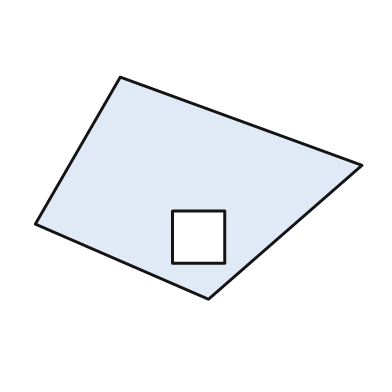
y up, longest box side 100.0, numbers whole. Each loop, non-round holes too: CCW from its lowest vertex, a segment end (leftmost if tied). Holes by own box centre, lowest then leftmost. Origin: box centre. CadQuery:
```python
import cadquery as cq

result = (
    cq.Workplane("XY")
    .moveTo(3.0, -34.0)
    .lineTo(50.0, 7.0)
    .lineTo(-24.0, 34.0)
    .lineTo(-50.0, -11.0)
    .close()
    .moveTo(-8.0, -23.0)
    .lineTo(8.0, -23.0)
    .lineTo(8.0, -7.0)
    .lineTo(-8.0, -7.0)
    .close()
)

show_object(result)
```